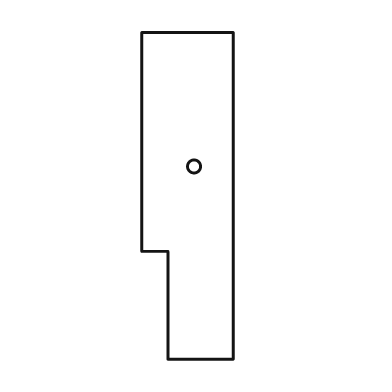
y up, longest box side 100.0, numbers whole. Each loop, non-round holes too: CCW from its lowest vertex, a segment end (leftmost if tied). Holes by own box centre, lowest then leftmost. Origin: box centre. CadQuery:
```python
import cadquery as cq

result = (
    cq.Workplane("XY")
    .moveTo(-6.0, -50.0)
    .lineTo(14.0, -50.0)
    .lineTo(14.0, 50.0)
    .lineTo(-14.0, 50.0)
    .lineTo(-14.0, -17.0)
    .lineTo(-6.0, -17.0)
    .close()
    .moveTo(2.0, 9.0)
    .circle(2.0)
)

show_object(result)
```